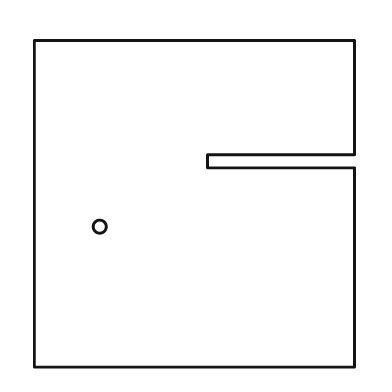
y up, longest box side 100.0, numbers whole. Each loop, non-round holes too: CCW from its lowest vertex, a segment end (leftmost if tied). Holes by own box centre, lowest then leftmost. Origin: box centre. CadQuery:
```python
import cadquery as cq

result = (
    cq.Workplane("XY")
    .moveTo(-49.0, -50.0)
    .lineTo(49.0, -50.0)
    .lineTo(49.0, 11.0)
    .lineTo(4.0, 11.0)
    .lineTo(4.0, 15.0)
    .lineTo(49.0, 15.0)
    .lineTo(49.0, 50.0)
    .lineTo(-49.0, 50.0)
    .close()
    .moveTo(-29.0, -7.0)
    .circle(2.0)
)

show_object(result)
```